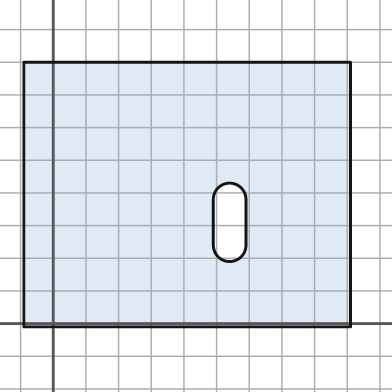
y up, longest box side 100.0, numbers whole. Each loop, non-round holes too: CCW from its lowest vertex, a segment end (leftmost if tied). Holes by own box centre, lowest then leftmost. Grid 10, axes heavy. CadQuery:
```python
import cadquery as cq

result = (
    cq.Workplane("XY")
    .moveTo(-9.0, -1.0)
    .lineTo(91.0, -1.0)
    .lineTo(91.0, 80.0)
    .lineTo(-9.0, 80.0)
    .close()
    .moveTo(49.0, 24.0)
    .threePointArc((54.0, 19.0), (59.0, 24.0))
    .lineTo(59.0, 38.0)
    .threePointArc((54.0, 43.0), (49.0, 38.0))
    .close()
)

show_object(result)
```